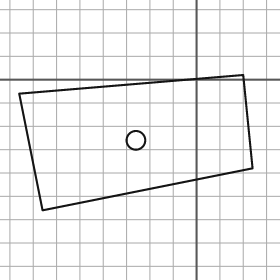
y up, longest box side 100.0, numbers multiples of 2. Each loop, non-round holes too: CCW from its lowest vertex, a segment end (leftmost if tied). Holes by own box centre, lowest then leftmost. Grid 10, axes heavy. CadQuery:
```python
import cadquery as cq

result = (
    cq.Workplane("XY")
    .moveTo(-66.0, -56.0)
    .lineTo(24.0, -38.0)
    .lineTo(20.0, 2.0)
    .lineTo(-76.0, -6.0)
    .close()
    .moveTo(-26.0, -26.0)
    .circle(4.0)
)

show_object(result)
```